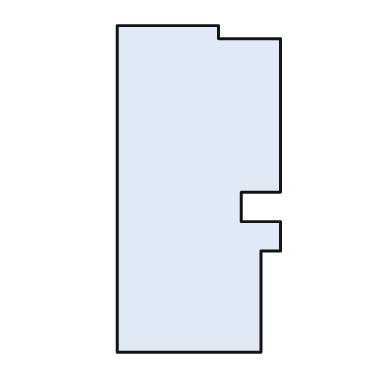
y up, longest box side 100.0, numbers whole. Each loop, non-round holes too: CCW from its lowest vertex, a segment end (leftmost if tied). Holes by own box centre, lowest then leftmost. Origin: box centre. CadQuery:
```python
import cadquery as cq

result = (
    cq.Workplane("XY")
    .moveTo(-25.0, -50.0)
    .lineTo(19.0, -50.0)
    .lineTo(19.0, -19.0)
    .lineTo(25.0, -19.0)
    .lineTo(25.0, -10.0)
    .lineTo(13.0, -10.0)
    .lineTo(13.0, -1.0)
    .lineTo(25.0, -1.0)
    .lineTo(25.0, 46.0)
    .lineTo(6.0, 46.0)
    .lineTo(6.0, 50.0)
    .lineTo(-25.0, 50.0)
    .close()
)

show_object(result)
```